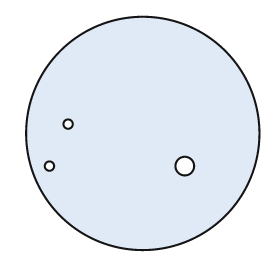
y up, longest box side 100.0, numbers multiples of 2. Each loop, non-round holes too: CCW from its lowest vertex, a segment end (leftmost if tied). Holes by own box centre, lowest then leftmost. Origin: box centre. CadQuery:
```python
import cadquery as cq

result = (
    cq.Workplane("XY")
    .moveTo(0.0, 0.0)
    .circle(50.0)
    .moveTo(-40.0, -14.0)
    .circle(2.0)
    .moveTo(18.0, -14.0)
    .circle(4.0)
    .moveTo(-32.0, 4.0)
    .circle(2.0)
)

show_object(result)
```